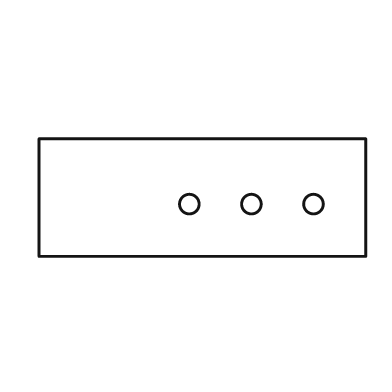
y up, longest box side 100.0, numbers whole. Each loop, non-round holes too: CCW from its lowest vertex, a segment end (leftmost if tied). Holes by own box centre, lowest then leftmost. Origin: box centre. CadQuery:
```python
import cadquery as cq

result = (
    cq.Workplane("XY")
    .moveTo(-50.0, -18.0)
    .lineTo(50.0, -18.0)
    .lineTo(50.0, 18.0)
    .lineTo(-50.0, 18.0)
    .close()
    .moveTo(-4.0, -2.0)
    .circle(3.0)
    .moveTo(15.0, -2.0)
    .circle(3.0)
    .moveTo(34.0, -2.0)
    .circle(3.0)
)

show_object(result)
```